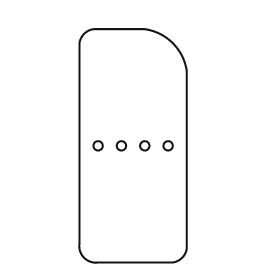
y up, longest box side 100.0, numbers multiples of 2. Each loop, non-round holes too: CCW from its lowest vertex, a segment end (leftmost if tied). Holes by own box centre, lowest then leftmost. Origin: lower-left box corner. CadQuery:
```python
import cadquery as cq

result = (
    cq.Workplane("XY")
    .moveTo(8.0, 0.0)
    .lineTo(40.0, 0.0)
    .threePointArc((44.0, 2.0), (46.0, 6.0))
    .lineTo(46.0, 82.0)
    .threePointArc((40.0, 94.0), (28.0, 100.0))
    .lineTo(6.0, 100.0)
    .threePointArc((2.0, 98.0), (0.0, 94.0))
    .lineTo(0.0, 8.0)
    .threePointArc((2.0, 2.0), (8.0, 0.0))
    .close()
    .moveTo(8.0, 50.0)
    .circle(2.0)
    .moveTo(18.0, 50.0)
    .circle(2.0)
    .moveTo(28.0, 50.0)
    .circle(2.0)
    .moveTo(38.0, 50.0)
    .circle(2.0)
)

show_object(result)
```